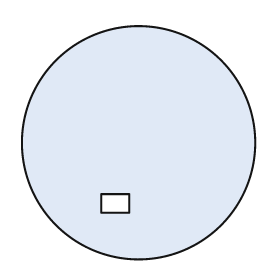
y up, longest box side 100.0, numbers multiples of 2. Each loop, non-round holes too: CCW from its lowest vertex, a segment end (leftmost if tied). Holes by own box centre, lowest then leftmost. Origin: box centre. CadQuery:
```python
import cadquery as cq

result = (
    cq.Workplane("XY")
    .moveTo(0.0, 0.0)
    .circle(50.0)
    .moveTo(-16.0, -30.0)
    .lineTo(-4.0, -30.0)
    .lineTo(-4.0, -22.0)
    .lineTo(-16.0, -22.0)
    .close()
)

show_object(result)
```